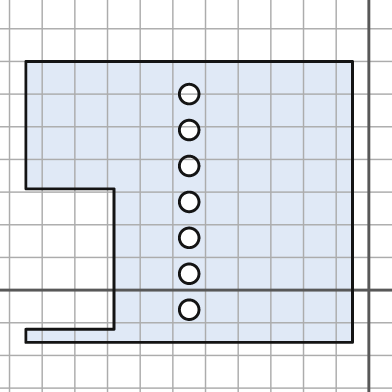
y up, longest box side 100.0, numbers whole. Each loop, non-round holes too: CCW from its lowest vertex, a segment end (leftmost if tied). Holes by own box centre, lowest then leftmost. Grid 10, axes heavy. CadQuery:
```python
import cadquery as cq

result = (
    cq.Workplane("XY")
    .moveTo(-105.0, -16.0)
    .lineTo(-5.0, -16.0)
    .lineTo(-5.0, 70.0)
    .lineTo(-105.0, 70.0)
    .lineTo(-105.0, 31.0)
    .lineTo(-78.0, 31.0)
    .lineTo(-78.0, -12.0)
    .lineTo(-105.0, -12.0)
    .close()
    .moveTo(-55.0, -6.0)
    .circle(3.0)
    .moveTo(-55.0, 5.0)
    .circle(3.0)
    .moveTo(-55.0, 16.0)
    .circle(3.0)
    .moveTo(-55.0, 27.0)
    .circle(3.0)
    .moveTo(-55.0, 38.0)
    .circle(3.0)
    .moveTo(-55.0, 49.0)
    .circle(3.0)
    .moveTo(-55.0, 60.0)
    .circle(3.0)
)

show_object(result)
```